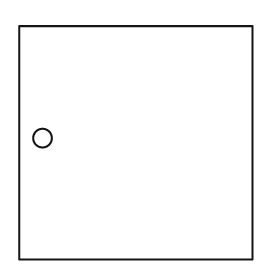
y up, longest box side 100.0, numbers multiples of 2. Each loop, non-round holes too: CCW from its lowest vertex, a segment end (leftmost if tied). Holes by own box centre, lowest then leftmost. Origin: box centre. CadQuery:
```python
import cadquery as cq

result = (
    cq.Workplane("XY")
    .moveTo(-50.0, -50.0)
    .lineTo(50.0, -50.0)
    .lineTo(50.0, 50.0)
    .lineTo(-50.0, 50.0)
    .close()
    .moveTo(-40.0, 2.0)
    .circle(4.0)
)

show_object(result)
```